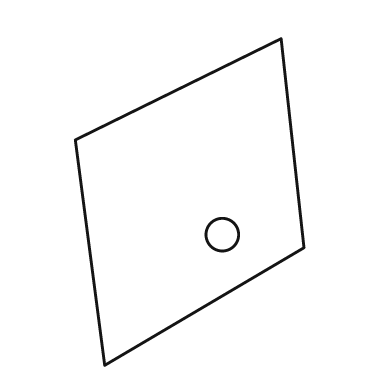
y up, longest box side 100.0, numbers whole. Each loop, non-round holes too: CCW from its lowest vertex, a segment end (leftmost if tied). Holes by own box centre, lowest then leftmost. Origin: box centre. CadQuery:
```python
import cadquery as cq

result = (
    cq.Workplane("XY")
    .moveTo(-26.0, -50.0)
    .lineTo(35.0, -14.0)
    .lineTo(28.0, 50.0)
    .lineTo(-35.0, 19.0)
    .close()
    .moveTo(10.0, -10.0)
    .circle(5.0)
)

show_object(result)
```